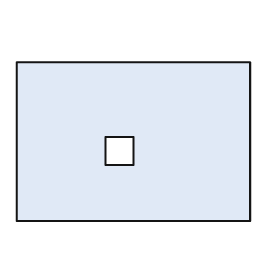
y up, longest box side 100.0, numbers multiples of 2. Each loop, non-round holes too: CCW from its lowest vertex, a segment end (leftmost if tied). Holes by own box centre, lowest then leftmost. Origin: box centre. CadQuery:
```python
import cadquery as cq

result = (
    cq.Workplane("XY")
    .moveTo(-50.0, -34.0)
    .lineTo(50.0, -34.0)
    .lineTo(50.0, 34.0)
    .lineTo(-50.0, 34.0)
    .close()
    .moveTo(-12.0, -10.0)
    .lineTo(0.0, -10.0)
    .lineTo(0.0, 2.0)
    .lineTo(-12.0, 2.0)
    .close()
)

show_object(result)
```